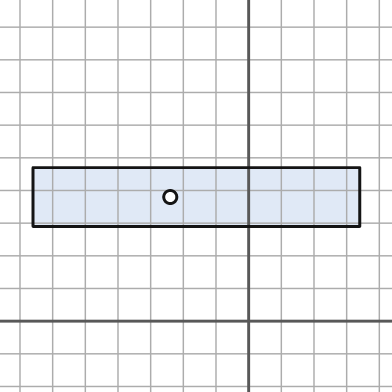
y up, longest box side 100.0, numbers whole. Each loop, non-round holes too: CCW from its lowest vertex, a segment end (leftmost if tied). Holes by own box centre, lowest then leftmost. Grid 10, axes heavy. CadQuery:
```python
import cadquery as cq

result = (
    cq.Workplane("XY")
    .moveTo(-66.0, 29.0)
    .lineTo(34.0, 29.0)
    .lineTo(34.0, 47.0)
    .lineTo(-66.0, 47.0)
    .close()
    .moveTo(-24.0, 38.0)
    .circle(2.0)
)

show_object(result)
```